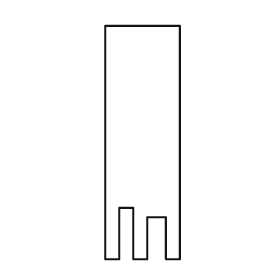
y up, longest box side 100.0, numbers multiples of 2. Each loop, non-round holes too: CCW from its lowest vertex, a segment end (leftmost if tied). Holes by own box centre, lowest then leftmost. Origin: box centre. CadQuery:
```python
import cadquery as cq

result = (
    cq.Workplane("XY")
    .moveTo(-16.0, -50.0)
    .lineTo(-10.0, -50.0)
    .lineTo(-10.0, -28.0)
    .lineTo(-4.0, -28.0)
    .lineTo(-4.0, -50.0)
    .lineTo(2.0, -50.0)
    .lineTo(2.0, -32.0)
    .lineTo(10.0, -32.0)
    .lineTo(10.0, -50.0)
    .lineTo(16.0, -50.0)
    .lineTo(16.0, 50.0)
    .lineTo(-16.0, 50.0)
    .close()
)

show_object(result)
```